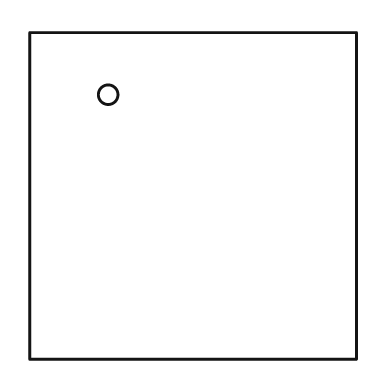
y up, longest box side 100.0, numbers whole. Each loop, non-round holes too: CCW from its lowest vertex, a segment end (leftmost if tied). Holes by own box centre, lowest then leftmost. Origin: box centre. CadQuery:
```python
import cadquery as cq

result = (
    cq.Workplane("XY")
    .moveTo(-50.0, -50.0)
    .lineTo(50.0, -50.0)
    .lineTo(50.0, 50.0)
    .lineTo(-50.0, 50.0)
    .close()
    .moveTo(-26.0, 31.0)
    .circle(3.0)
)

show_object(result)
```